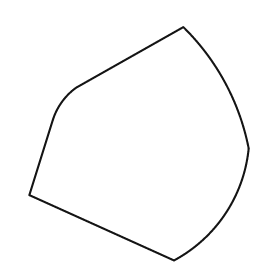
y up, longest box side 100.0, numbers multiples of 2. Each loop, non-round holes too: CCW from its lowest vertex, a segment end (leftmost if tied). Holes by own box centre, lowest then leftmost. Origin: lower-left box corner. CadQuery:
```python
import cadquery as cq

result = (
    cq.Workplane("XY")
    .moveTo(62.0, 0.0)
    .threePointArc((84.0, 20.0), (94.0, 48.0))
    .threePointArc((84.0, 76.0), (66.0, 100.0))
    .lineTo(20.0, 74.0)
    .threePointArc((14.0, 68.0), (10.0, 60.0))
    .lineTo(0.0, 28.0)
    .close()
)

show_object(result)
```